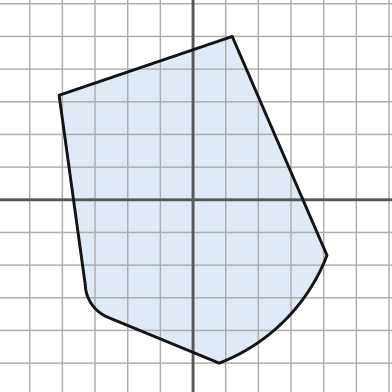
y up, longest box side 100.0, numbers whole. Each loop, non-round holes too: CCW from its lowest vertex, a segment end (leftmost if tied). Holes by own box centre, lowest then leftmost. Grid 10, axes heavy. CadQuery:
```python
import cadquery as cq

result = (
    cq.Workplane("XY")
    .moveTo(8.0, -50.0)
    .threePointArc((28.0, -37.0), (41.0, -17.0))
    .lineTo(12.0, 50.0)
    .lineTo(-41.0, 32.0)
    .lineTo(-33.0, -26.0)
    .threePointArc((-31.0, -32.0), (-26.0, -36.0))
    .close()
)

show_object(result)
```